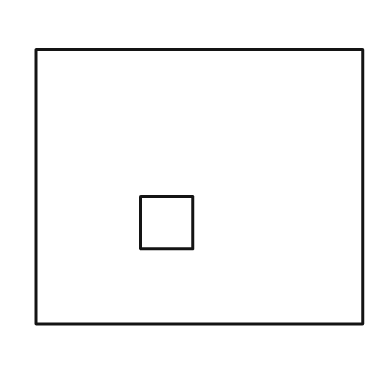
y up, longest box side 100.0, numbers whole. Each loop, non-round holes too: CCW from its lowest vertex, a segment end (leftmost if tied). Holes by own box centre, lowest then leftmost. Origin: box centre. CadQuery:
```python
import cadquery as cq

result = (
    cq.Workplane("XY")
    .moveTo(-50.0, -42.0)
    .lineTo(50.0, -42.0)
    .lineTo(50.0, 42.0)
    .lineTo(-50.0, 42.0)
    .close()
    .moveTo(-18.0, -19.0)
    .lineTo(-2.0, -19.0)
    .lineTo(-2.0, -3.0)
    .lineTo(-18.0, -3.0)
    .close()
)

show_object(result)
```